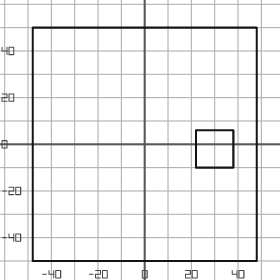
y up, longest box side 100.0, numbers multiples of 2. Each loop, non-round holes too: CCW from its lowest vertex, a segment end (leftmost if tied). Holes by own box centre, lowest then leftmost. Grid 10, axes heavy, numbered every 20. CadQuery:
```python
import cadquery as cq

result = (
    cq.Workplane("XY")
    .moveTo(-48.0, -50.0)
    .lineTo(48.0, -50.0)
    .lineTo(48.0, 50.0)
    .lineTo(-48.0, 50.0)
    .close()
    .moveTo(22.0, -10.0)
    .lineTo(38.0, -10.0)
    .lineTo(38.0, 6.0)
    .lineTo(22.0, 6.0)
    .close()
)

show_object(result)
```